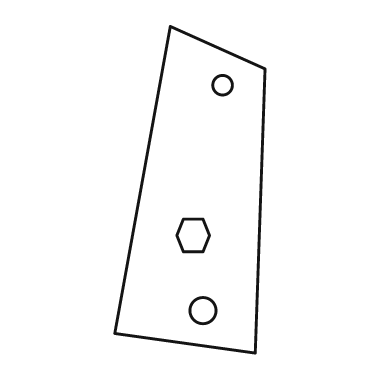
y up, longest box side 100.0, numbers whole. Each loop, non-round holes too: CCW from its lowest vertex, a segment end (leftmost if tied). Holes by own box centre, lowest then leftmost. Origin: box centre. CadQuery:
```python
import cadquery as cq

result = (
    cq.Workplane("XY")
    .moveTo(20.0, -50.0)
    .lineTo(23.0, 37.0)
    .lineTo(-6.0, 50.0)
    .lineTo(-23.0, -44.0)
    .close()
    .moveTo(4.0, -37.0)
    .circle(4.0)
    .moveTo(-2.0, -19.0)
    .lineTo(4.0, -19.0)
    .lineTo(6.0, -14.0)
    .lineTo(4.0, -9.0)
    .lineTo(-2.0, -9.0)
    .lineTo(-4.0, -14.0)
    .close()
    .moveTo(10.0, 32.0)
    .circle(3.0)
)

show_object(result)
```